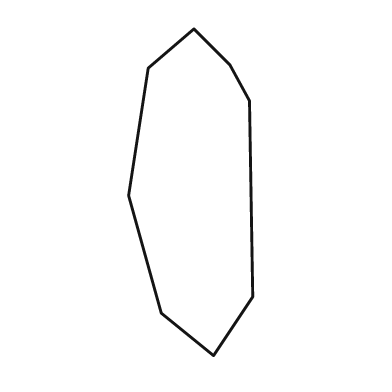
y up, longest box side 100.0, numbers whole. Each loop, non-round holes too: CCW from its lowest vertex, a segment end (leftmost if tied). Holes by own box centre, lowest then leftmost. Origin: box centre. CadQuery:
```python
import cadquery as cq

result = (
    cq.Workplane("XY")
    .moveTo(7.0, -50.0)
    .lineTo(19.0, -32.0)
    .lineTo(18.0, 28.0)
    .lineTo(12.0, 39.0)
    .lineTo(1.0, 50.0)
    .lineTo(-13.0, 38.0)
    .lineTo(-19.0, -1.0)
    .lineTo(-9.0, -37.0)
    .close()
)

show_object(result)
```